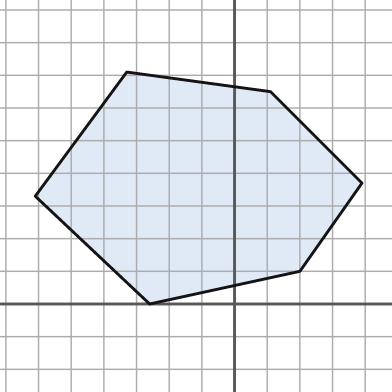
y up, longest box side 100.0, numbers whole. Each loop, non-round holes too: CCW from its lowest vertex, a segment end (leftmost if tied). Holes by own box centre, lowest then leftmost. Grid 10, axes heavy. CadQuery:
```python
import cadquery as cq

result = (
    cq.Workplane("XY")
    .moveTo(-26.0, 0.0)
    .lineTo(20.0, 10.0)
    .lineTo(39.0, 37.0)
    .lineTo(11.0, 65.0)
    .lineTo(-33.0, 71.0)
    .lineTo(-61.0, 33.0)
    .close()
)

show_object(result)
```